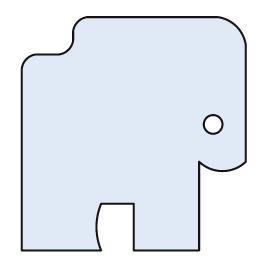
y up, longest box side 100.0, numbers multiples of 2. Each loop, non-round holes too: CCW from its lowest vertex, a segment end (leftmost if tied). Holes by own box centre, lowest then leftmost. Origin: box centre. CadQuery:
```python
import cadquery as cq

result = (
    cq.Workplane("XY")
    .moveTo(-48.0, -50.0)
    .lineTo(-14.0, -50.0)
    .threePointArc((-16.0, -40.0), (-14.0, -30.0))
    .lineTo(0.0, -30.0)
    .lineTo(0.0, -50.0)
    .lineTo(28.0, -50.0)
    .lineTo(28.0, -12.0)
    .threePointArc((38.0, -16.0), (48.0, -12.0))
    .lineTo(48.0, 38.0)
    .threePointArc((44.0, 46.0), (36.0, 50.0))
    .lineTo(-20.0, 50.0)
    .threePointArc((-24.0, 48.0), (-26.0, 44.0))
    .lineTo(-26.0, 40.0)
    .threePointArc((-28.0, 36.0), (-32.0, 34.0))
    .lineTo(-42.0, 34.0)
    .threePointArc((-46.0, 32.0), (-48.0, 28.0))
    .close()
    .moveTo(34.0, 4.0)
    .circle(4.0)
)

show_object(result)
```